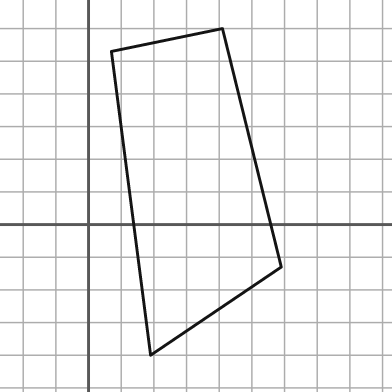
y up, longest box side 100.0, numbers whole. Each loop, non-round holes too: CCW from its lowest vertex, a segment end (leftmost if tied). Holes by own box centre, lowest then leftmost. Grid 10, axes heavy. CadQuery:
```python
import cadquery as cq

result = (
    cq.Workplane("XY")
    .moveTo(19.0, -40.0)
    .lineTo(59.0, -13.0)
    .lineTo(41.0, 60.0)
    .lineTo(7.0, 53.0)
    .close()
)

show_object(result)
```